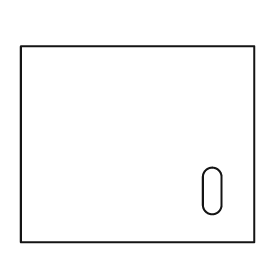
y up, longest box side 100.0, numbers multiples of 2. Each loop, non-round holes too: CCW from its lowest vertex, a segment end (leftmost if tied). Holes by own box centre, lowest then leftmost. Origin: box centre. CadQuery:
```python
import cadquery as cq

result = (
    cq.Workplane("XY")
    .moveTo(-50.0, -42.0)
    .lineTo(50.0, -42.0)
    .lineTo(50.0, 42.0)
    .lineTo(-50.0, 42.0)
    .close()
    .moveTo(28.0, -26.0)
    .threePointArc((32.0, -30.0), (36.0, -26.0))
    .lineTo(36.0, -14.0)
    .threePointArc((32.0, -10.0), (28.0, -14.0))
    .close()
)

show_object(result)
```